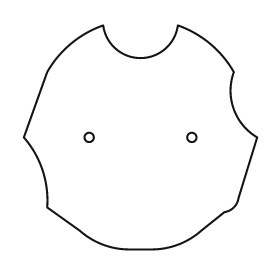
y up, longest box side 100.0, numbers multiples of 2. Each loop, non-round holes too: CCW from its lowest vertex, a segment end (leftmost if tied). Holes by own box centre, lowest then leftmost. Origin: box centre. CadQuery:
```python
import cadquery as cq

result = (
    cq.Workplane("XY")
    .moveTo(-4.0, -48.0)
    .lineTo(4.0, -48.0)
    .threePointArc((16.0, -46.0), (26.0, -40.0))
    .lineTo(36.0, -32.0)
    .threePointArc((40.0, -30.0), (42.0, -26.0))
    .lineTo(50.0, 0.0)
    .threePointArc((40.0, 12.0), (40.0, 28.0))
    .threePointArc((30.0, 40.0), (16.0, 48.0))
    .threePointArc((0.0, 34.0), (-16.0, 48.0))
    .threePointArc((-30.0, 40.0), (-40.0, 28.0))
    .lineTo(-50.0, 0.0)
    .threePointArc((-42.0, -14.0), (-40.0, -30.0))
    .lineTo(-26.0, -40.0)
    .threePointArc((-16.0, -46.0), (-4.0, -48.0))
    .close()
    .moveTo(-22.0, 0.0)
    .circle(2.0)
    .moveTo(22.0, 0.0)
    .circle(2.0)
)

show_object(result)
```